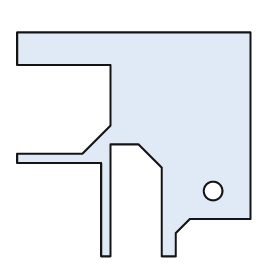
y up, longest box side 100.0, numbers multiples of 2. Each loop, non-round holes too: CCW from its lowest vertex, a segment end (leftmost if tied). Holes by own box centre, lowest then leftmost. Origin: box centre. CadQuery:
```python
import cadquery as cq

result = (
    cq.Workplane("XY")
    .moveTo(-14.0, -48.0)
    .lineTo(-10.0, -48.0)
    .lineTo(-10.0, 0.0)
    .lineTo(2.0, 0.0)
    .lineTo(12.0, -10.0)
    .lineTo(12.0, -48.0)
    .lineTo(18.0, -48.0)
    .lineTo(18.0, -38.0)
    .lineTo(24.0, -32.0)
    .lineTo(50.0, -32.0)
    .lineTo(50.0, 48.0)
    .lineTo(-50.0, 48.0)
    .lineTo(-50.0, 34.0)
    .lineTo(-10.0, 34.0)
    .lineTo(-10.0, 8.0)
    .lineTo(-22.0, -4.0)
    .lineTo(-50.0, -4.0)
    .lineTo(-50.0, -8.0)
    .lineTo(-14.0, -8.0)
    .close()
    .moveTo(34.0, -20.0)
    .circle(4.0)
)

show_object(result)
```